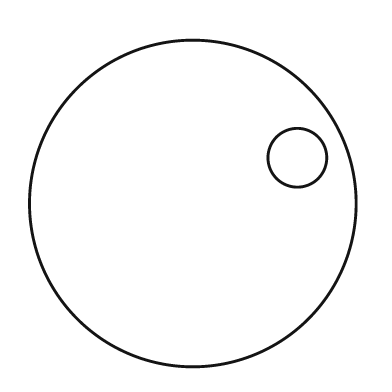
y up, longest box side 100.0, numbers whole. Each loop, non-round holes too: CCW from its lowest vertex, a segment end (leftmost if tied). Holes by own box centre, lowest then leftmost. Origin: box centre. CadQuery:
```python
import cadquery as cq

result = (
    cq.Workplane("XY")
    .moveTo(0.0, 0.0)
    .circle(50.0)
    .moveTo(32.0, 14.0)
    .circle(9.0)
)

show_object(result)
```